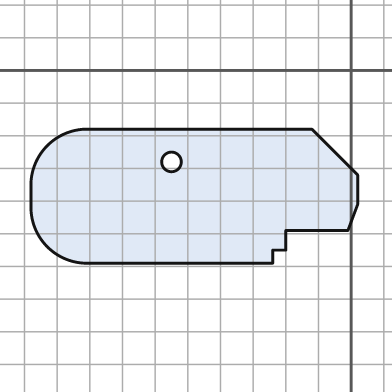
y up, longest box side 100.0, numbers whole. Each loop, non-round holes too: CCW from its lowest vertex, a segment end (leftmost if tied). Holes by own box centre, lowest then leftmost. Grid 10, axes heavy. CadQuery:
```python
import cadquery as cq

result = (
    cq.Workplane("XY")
    .moveTo(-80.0, -59.0)
    .lineTo(-24.0, -59.0)
    .lineTo(-24.0, -55.0)
    .lineTo(-20.0, -55.0)
    .lineTo(-20.0, -49.0)
    .lineTo(-1.0, -49.0)
    .lineTo(2.0, -41.0)
    .lineTo(2.0, -32.0)
    .lineTo(-12.0, -18.0)
    .lineTo(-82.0, -18.0)
    .threePointArc((-93.0, -23.0), (-98.0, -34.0))
    .lineTo(-98.0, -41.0)
    .threePointArc((-93.0, -54.0), (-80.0, -59.0))
    .close()
    .moveTo(-55.0, -28.0)
    .circle(3.0)
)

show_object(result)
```